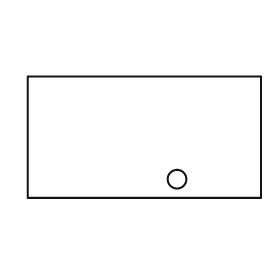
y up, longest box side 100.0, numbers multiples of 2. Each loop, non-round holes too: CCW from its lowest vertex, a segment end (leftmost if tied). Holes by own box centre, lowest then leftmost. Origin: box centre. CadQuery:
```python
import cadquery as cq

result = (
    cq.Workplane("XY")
    .moveTo(-50.0, -26.0)
    .lineTo(50.0, -26.0)
    .lineTo(50.0, 26.0)
    .lineTo(-50.0, 26.0)
    .close()
    .moveTo(14.0, -18.0)
    .circle(4.0)
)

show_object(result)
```